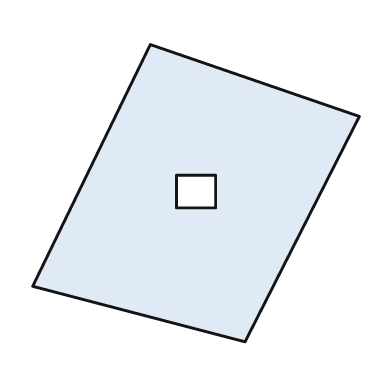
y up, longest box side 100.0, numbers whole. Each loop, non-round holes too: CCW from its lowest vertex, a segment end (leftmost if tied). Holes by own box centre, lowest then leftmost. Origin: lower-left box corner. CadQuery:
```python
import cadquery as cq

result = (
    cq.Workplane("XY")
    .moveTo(65.0, 0.0)
    .lineTo(100.0, 69.0)
    .lineTo(36.0, 91.0)
    .lineTo(0.0, 17.0)
    .close()
    .moveTo(44.0, 41.0)
    .lineTo(56.0, 41.0)
    .lineTo(56.0, 51.0)
    .lineTo(44.0, 51.0)
    .close()
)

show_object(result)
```